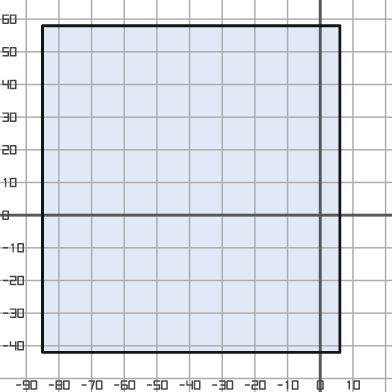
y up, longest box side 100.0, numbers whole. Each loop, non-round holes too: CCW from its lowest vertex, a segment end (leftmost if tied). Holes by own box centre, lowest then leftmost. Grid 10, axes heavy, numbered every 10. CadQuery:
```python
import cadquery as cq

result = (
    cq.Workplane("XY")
    .moveTo(-85.0, -42.0)
    .lineTo(6.0, -42.0)
    .lineTo(6.0, 58.0)
    .lineTo(-85.0, 58.0)
    .close()
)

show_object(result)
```